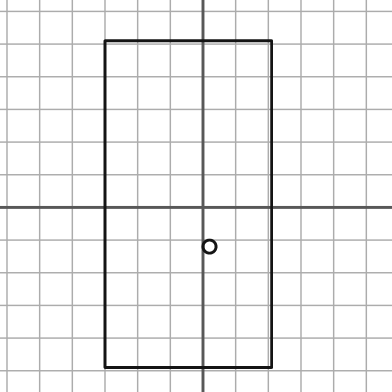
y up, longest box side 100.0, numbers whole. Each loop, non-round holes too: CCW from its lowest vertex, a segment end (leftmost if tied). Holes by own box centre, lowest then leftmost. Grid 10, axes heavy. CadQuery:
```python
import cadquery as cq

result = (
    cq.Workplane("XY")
    .moveTo(-30.0, -49.0)
    .lineTo(21.0, -49.0)
    .lineTo(21.0, 51.0)
    .lineTo(-30.0, 51.0)
    .close()
    .moveTo(2.0, -12.0)
    .circle(2.0)
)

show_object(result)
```